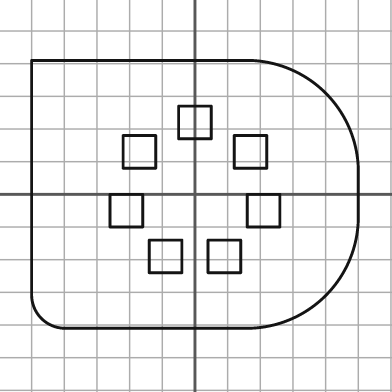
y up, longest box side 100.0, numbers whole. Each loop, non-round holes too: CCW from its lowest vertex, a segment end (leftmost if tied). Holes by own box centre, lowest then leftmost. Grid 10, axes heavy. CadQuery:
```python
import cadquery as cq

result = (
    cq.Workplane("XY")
    .moveTo(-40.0, -41.0)
    .lineTo(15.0, -41.0)
    .threePointArc((40.0, -31.0), (50.0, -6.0))
    .lineTo(50.0, 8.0)
    .threePointArc((40.0, 31.0), (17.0, 41.0))
    .lineTo(-50.0, 41.0)
    .lineTo(-50.0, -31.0)
    .threePointArc((-47.0, -38.0), (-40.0, -41.0))
    .close()
    .moveTo(-14.0, -24.0)
    .lineTo(-4.0, -24.0)
    .lineTo(-4.0, -14.0)
    .lineTo(-14.0, -14.0)
    .close()
    .moveTo(4.0, -24.0)
    .lineTo(14.0, -24.0)
    .lineTo(14.0, -14.0)
    .lineTo(4.0, -14.0)
    .close()
    .moveTo(-26.0, -10.0)
    .lineTo(-16.0, -10.0)
    .lineTo(-16.0, 0.0)
    .lineTo(-26.0, 0.0)
    .close()
    .moveTo(16.0, -10.0)
    .lineTo(26.0, -10.0)
    .lineTo(26.0, 0.0)
    .lineTo(16.0, 0.0)
    .close()
    .moveTo(-22.0, 8.0)
    .lineTo(-12.0, 8.0)
    .lineTo(-12.0, 18.0)
    .lineTo(-22.0, 18.0)
    .close()
    .moveTo(12.0, 8.0)
    .lineTo(22.0, 8.0)
    .lineTo(22.0, 18.0)
    .lineTo(12.0, 18.0)
    .close()
    .moveTo(-5.0, 17.0)
    .lineTo(5.0, 17.0)
    .lineTo(5.0, 27.0)
    .lineTo(-5.0, 27.0)
    .close()
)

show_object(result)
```